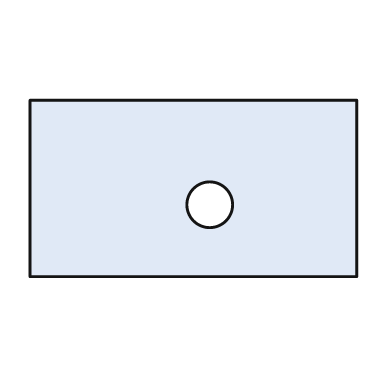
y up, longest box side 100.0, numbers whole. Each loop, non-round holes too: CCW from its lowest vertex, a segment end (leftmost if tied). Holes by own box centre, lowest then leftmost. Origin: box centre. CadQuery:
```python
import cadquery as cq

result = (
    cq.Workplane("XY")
    .moveTo(-50.0, -27.0)
    .lineTo(50.0, -27.0)
    .lineTo(50.0, 27.0)
    .lineTo(-50.0, 27.0)
    .close()
    .moveTo(5.0, -5.0)
    .circle(7.0)
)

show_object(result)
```